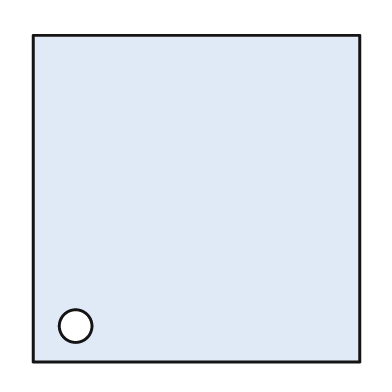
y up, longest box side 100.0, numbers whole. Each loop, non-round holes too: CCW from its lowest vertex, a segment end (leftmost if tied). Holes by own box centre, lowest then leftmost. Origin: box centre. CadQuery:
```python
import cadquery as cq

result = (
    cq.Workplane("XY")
    .moveTo(-50.0, -50.0)
    .lineTo(50.0, -50.0)
    .lineTo(50.0, 50.0)
    .lineTo(-50.0, 50.0)
    .close()
    .moveTo(-37.0, -39.0)
    .circle(5.0)
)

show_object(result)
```